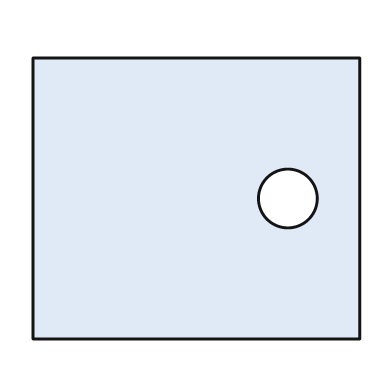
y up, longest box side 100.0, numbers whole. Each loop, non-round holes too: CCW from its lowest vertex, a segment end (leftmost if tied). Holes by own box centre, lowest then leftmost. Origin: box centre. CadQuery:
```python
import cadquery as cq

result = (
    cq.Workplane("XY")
    .moveTo(-50.0, -43.0)
    .lineTo(50.0, -43.0)
    .lineTo(50.0, 43.0)
    .lineTo(-50.0, 43.0)
    .close()
    .moveTo(28.0, 0.0)
    .circle(9.0)
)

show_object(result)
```